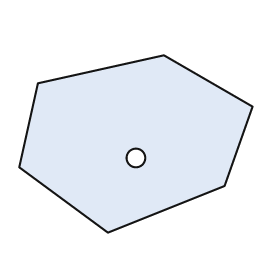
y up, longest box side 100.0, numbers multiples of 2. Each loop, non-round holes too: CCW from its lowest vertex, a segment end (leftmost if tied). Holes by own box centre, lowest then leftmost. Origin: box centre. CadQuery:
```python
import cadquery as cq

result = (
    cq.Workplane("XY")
    .moveTo(-12.0, -38.0)
    .lineTo(38.0, -18.0)
    .lineTo(50.0, 16.0)
    .lineTo(12.0, 38.0)
    .lineTo(-42.0, 26.0)
    .lineTo(-50.0, -10.0)
    .close()
    .moveTo(0.0, -6.0)
    .circle(4.0)
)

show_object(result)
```